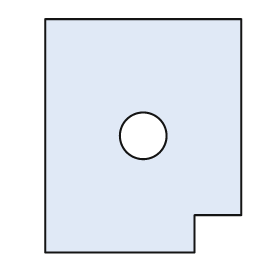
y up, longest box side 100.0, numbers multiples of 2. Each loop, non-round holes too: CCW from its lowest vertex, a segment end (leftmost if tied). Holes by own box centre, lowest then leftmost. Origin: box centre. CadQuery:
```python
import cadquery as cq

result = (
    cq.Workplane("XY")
    .moveTo(-42.0, -50.0)
    .lineTo(22.0, -50.0)
    .lineTo(22.0, -34.0)
    .lineTo(42.0, -34.0)
    .lineTo(42.0, 50.0)
    .lineTo(-42.0, 50.0)
    .close()
    .moveTo(0.0, 0.0)
    .circle(10.0)
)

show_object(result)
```